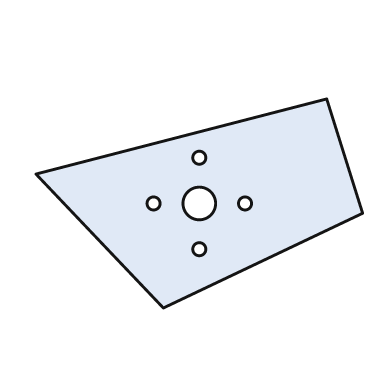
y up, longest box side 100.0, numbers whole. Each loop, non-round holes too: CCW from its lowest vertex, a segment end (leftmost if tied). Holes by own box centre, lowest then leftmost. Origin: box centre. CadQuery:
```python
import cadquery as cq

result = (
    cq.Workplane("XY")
    .moveTo(-11.0, -32.0)
    .lineTo(50.0, -3.0)
    .lineTo(39.0, 32.0)
    .lineTo(-50.0, 9.0)
    .close()
    .moveTo(0.0, -14.0)
    .circle(2.0)
    .moveTo(-14.0, 0.0)
    .circle(2.0)
    .moveTo(0.0, 0.0)
    .circle(5.0)
    .moveTo(14.0, 0.0)
    .circle(2.0)
    .moveTo(0.0, 14.0)
    .circle(2.0)
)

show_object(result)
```